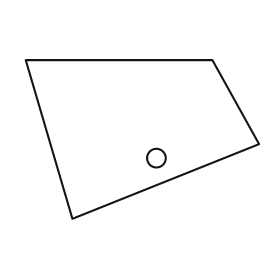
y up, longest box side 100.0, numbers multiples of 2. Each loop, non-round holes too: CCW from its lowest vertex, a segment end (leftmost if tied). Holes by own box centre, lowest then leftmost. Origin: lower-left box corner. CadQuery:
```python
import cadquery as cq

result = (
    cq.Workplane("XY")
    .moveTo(20.0, 0.0)
    .lineTo(100.0, 32.0)
    .lineTo(80.0, 68.0)
    .lineTo(0.0, 68.0)
    .close()
    .moveTo(56.0, 26.0)
    .circle(4.0)
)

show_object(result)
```